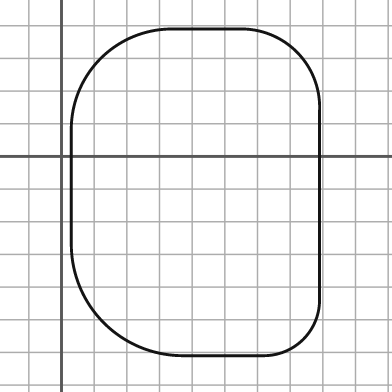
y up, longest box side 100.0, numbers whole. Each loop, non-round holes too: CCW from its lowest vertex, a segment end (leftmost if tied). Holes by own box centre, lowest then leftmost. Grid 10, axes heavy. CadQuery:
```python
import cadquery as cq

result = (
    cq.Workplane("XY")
    .moveTo(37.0, -61.0)
    .lineTo(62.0, -61.0)
    .threePointArc((74.0, -56.0), (79.0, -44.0))
    .lineTo(79.0, 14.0)
    .threePointArc((72.0, 32.0), (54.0, 39.0))
    .lineTo(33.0, 39.0)
    .threePointArc((12.0, 30.0), (3.0, 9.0))
    .lineTo(3.0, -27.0)
    .threePointArc((13.0, -51.0), (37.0, -61.0))
    .close()
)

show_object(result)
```